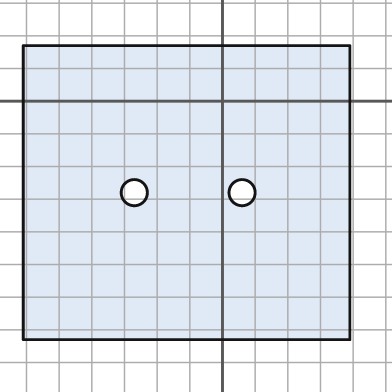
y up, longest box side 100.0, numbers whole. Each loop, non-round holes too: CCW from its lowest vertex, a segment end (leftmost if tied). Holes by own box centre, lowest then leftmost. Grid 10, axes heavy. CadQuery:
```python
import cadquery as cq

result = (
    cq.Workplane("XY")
    .moveTo(-61.0, -73.0)
    .lineTo(39.0, -73.0)
    .lineTo(39.0, 17.0)
    .lineTo(-61.0, 17.0)
    .close()
    .moveTo(-27.0, -28.0)
    .circle(4.0)
    .moveTo(6.0, -28.0)
    .circle(4.0)
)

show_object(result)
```